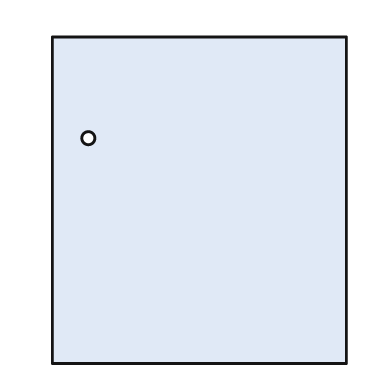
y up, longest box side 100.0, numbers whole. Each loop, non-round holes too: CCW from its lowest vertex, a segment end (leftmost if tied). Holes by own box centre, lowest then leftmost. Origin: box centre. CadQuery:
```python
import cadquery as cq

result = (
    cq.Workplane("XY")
    .moveTo(-45.0, -50.0)
    .lineTo(45.0, -50.0)
    .lineTo(45.0, 50.0)
    .lineTo(-45.0, 50.0)
    .close()
    .moveTo(-34.0, 19.0)
    .circle(2.0)
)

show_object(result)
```